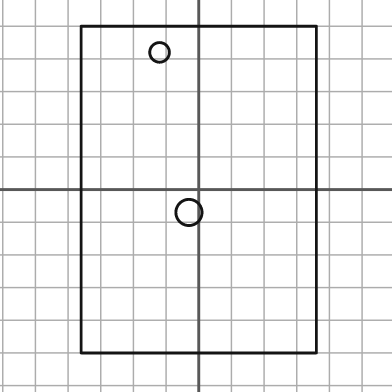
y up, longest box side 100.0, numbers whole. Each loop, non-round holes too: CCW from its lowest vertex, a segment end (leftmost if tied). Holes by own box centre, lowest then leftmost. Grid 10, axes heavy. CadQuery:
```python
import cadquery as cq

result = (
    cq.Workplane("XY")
    .moveTo(-36.0, -50.0)
    .lineTo(36.0, -50.0)
    .lineTo(36.0, 50.0)
    .lineTo(-36.0, 50.0)
    .close()
    .moveTo(-3.0, -7.0)
    .circle(4.0)
    .moveTo(-12.0, 42.0)
    .circle(3.0)
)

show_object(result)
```